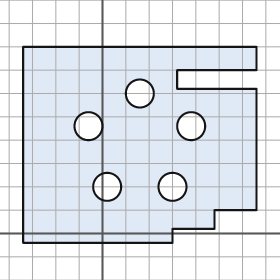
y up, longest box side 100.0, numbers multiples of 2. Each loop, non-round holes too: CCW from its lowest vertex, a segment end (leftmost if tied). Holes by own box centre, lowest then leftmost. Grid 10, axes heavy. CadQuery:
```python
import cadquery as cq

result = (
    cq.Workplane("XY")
    .moveTo(-34.0, -4.0)
    .lineTo(30.0, -4.0)
    .lineTo(30.0, 2.0)
    .lineTo(48.0, 2.0)
    .lineTo(48.0, 10.0)
    .lineTo(66.0, 10.0)
    .lineTo(66.0, 62.0)
    .lineTo(32.0, 62.0)
    .lineTo(32.0, 70.0)
    .lineTo(66.0, 70.0)
    .lineTo(66.0, 80.0)
    .lineTo(-34.0, 80.0)
    .close()
    .moveTo(2.0, 20.0)
    .circle(6.0)
    .moveTo(30.0, 20.0)
    .circle(6.0)
    .moveTo(-6.0, 46.0)
    .circle(6.0)
    .moveTo(38.0, 46.0)
    .circle(6.0)
    .moveTo(16.0, 60.0)
    .circle(6.0)
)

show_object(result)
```